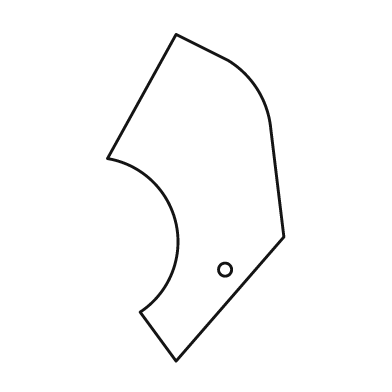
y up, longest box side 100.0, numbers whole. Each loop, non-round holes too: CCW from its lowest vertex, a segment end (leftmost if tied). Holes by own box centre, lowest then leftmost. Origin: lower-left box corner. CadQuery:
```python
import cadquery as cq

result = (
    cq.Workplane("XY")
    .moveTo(21.0, 0.0)
    .lineTo(54.0, 38.0)
    .lineTo(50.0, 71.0)
    .threePointArc((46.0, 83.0), (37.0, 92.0))
    .lineTo(21.0, 100.0)
    .lineTo(0.0, 62.0)
    .threePointArc((21.0, 42.0), (10.0, 15.0))
    .close()
    .moveTo(36.0, 28.0)
    .circle(2.0)
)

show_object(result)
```